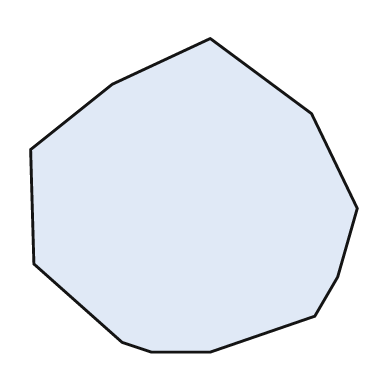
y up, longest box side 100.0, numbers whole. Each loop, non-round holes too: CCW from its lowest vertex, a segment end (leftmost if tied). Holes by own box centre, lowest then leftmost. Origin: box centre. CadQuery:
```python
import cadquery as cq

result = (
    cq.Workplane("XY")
    .moveTo(-13.0, -48.0)
    .lineTo(5.0, -48.0)
    .lineTo(37.0, -37.0)
    .lineTo(44.0, -25.0)
    .lineTo(50.0, -4.0)
    .lineTo(36.0, 25.0)
    .lineTo(5.0, 48.0)
    .lineTo(-25.0, 34.0)
    .lineTo(-50.0, 14.0)
    .lineTo(-49.0, -21.0)
    .lineTo(-22.0, -45.0)
    .close()
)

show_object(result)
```